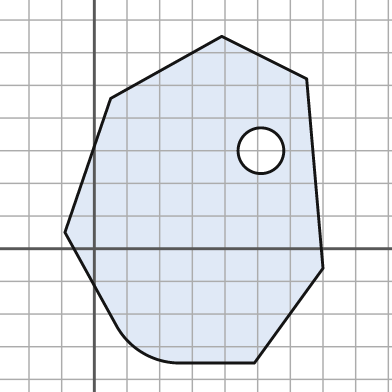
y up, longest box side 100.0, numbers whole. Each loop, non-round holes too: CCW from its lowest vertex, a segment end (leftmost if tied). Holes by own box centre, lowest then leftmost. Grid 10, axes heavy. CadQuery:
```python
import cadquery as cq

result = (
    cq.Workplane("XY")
    .moveTo(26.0, -35.0)
    .lineTo(49.0, -35.0)
    .lineTo(70.0, -6.0)
    .lineTo(65.0, 52.0)
    .lineTo(39.0, 65.0)
    .lineTo(5.0, 46.0)
    .lineTo(-9.0, 5.0)
    .lineTo(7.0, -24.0)
    .threePointArc((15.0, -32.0), (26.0, -35.0))
    .close()
    .moveTo(51.0, 30.0)
    .circle(7.0)
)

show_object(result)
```